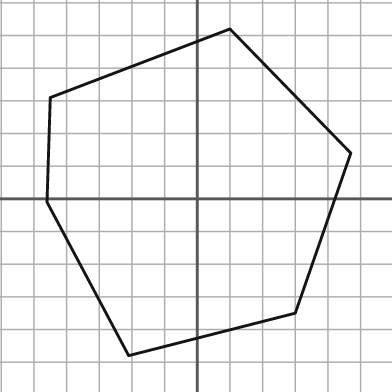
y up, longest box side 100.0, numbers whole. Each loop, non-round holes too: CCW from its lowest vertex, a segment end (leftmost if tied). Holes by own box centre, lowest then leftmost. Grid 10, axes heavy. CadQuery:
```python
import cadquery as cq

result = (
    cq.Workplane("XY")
    .moveTo(-21.0, -48.0)
    .lineTo(30.0, -35.0)
    .lineTo(47.0, 14.0)
    .lineTo(10.0, 52.0)
    .lineTo(-45.0, 31.0)
    .lineTo(-46.0, -1.0)
    .close()
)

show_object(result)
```